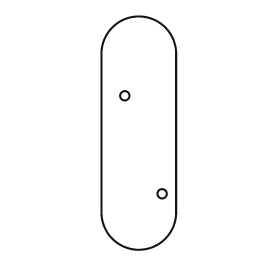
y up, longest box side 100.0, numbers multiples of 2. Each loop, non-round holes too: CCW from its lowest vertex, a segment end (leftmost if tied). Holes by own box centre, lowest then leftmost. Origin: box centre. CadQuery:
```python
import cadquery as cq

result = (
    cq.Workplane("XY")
    .moveTo(-16.0, -34.0)
    .threePointArc((0.0, -50.0), (16.0, -34.0))
    .lineTo(16.0, 34.0)
    .threePointArc((0.0, 50.0), (-16.0, 34.0))
    .close()
    .moveTo(10.0, -26.0)
    .circle(2.0)
    .moveTo(-6.0, 16.0)
    .circle(2.0)
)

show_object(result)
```